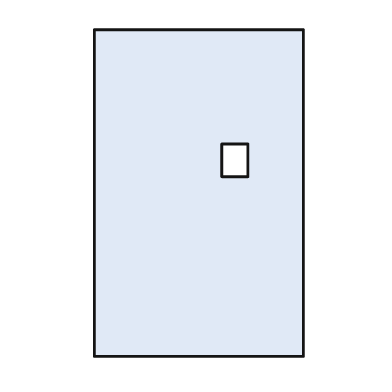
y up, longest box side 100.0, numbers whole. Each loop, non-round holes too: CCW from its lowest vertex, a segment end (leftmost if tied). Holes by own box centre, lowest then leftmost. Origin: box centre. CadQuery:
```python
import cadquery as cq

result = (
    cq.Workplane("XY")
    .moveTo(-32.0, -50.0)
    .lineTo(32.0, -50.0)
    .lineTo(32.0, 50.0)
    .lineTo(-32.0, 50.0)
    .close()
    .moveTo(7.0, 5.0)
    .lineTo(15.0, 5.0)
    .lineTo(15.0, 15.0)
    .lineTo(7.0, 15.0)
    .close()
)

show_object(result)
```